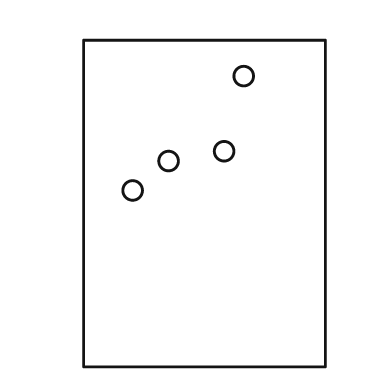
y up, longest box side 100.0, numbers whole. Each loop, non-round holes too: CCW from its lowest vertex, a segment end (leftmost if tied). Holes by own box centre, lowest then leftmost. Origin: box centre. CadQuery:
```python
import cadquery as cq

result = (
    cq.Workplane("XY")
    .moveTo(-37.0, -50.0)
    .lineTo(37.0, -50.0)
    .lineTo(37.0, 50.0)
    .lineTo(-37.0, 50.0)
    .close()
    .moveTo(-22.0, 4.0)
    .circle(3.0)
    .moveTo(-11.0, 13.0)
    .circle(3.0)
    .moveTo(6.0, 16.0)
    .circle(3.0)
    .moveTo(12.0, 39.0)
    .circle(3.0)
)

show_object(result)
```